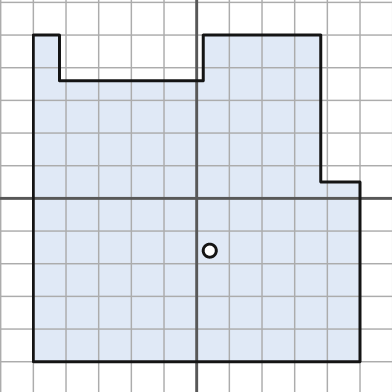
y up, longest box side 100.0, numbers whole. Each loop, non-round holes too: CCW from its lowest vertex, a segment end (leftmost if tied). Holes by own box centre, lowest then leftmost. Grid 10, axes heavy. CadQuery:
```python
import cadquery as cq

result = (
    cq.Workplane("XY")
    .moveTo(-50.0, -50.0)
    .lineTo(50.0, -50.0)
    .lineTo(50.0, 5.0)
    .lineTo(38.0, 5.0)
    .lineTo(38.0, 50.0)
    .lineTo(2.0, 50.0)
    .lineTo(2.0, 36.0)
    .lineTo(-42.0, 36.0)
    .lineTo(-42.0, 50.0)
    .lineTo(-50.0, 50.0)
    .close()
    .moveTo(4.0, -16.0)
    .circle(2.0)
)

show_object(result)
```